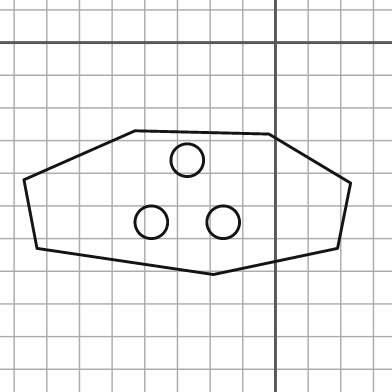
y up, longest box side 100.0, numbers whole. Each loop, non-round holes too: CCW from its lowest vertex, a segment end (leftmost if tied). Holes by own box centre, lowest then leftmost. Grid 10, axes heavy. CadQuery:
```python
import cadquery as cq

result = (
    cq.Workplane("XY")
    .moveTo(-19.0, -71.0)
    .lineTo(19.0, -63.0)
    .lineTo(23.0, -43.0)
    .lineTo(-2.0, -28.0)
    .lineTo(-43.0, -27.0)
    .lineTo(-77.0, -42.0)
    .lineTo(-73.0, -63.0)
    .close()
    .moveTo(-38.0, -55.0)
    .circle(5.0)
    .moveTo(-16.0, -55.0)
    .circle(5.0)
    .moveTo(-27.0, -36.0)
    .circle(5.0)
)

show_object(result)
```